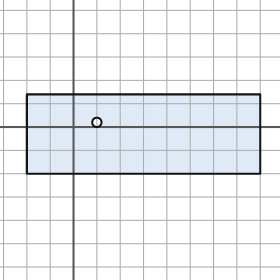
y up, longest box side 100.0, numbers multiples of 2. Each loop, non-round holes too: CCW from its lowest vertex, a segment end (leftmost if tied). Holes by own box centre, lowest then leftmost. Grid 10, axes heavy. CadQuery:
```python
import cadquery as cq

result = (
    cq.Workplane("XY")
    .moveTo(-20.0, -20.0)
    .lineTo(80.0, -20.0)
    .lineTo(80.0, 14.0)
    .lineTo(-20.0, 14.0)
    .close()
    .moveTo(10.0, 2.0)
    .circle(2.0)
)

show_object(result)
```